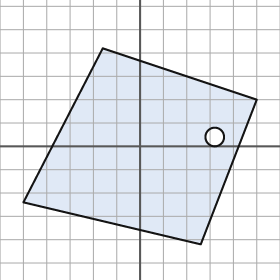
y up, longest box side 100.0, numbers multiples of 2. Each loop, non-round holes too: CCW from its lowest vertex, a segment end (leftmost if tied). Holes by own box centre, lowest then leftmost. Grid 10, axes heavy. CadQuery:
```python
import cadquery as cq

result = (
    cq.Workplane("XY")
    .moveTo(26.0, -42.0)
    .lineTo(50.0, 20.0)
    .lineTo(-16.0, 42.0)
    .lineTo(-50.0, -24.0)
    .close()
    .moveTo(32.0, 4.0)
    .circle(4.0)
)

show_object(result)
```